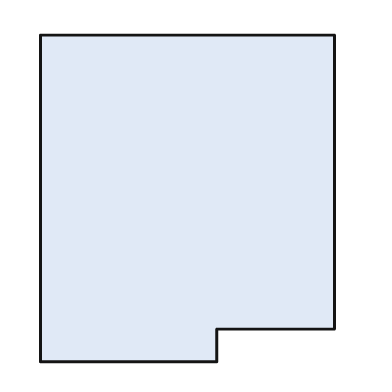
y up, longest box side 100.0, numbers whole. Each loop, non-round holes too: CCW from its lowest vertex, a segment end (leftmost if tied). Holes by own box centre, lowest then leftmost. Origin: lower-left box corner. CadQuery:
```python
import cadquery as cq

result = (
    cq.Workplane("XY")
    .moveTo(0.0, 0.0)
    .lineTo(54.0, 0.0)
    .lineTo(54.0, 10.0)
    .lineTo(90.0, 10.0)
    .lineTo(90.0, 100.0)
    .lineTo(0.0, 100.0)
    .close()
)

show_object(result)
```